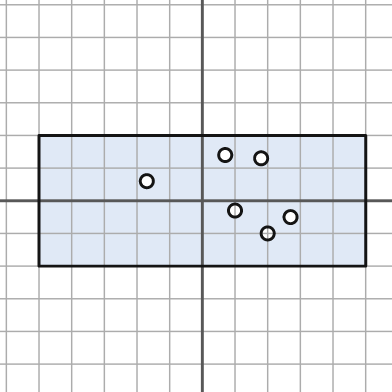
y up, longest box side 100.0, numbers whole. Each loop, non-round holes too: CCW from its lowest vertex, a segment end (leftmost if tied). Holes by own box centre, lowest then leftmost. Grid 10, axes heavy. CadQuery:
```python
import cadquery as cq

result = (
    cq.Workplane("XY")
    .moveTo(-50.0, -20.0)
    .lineTo(50.0, -20.0)
    .lineTo(50.0, 20.0)
    .lineTo(-50.0, 20.0)
    .close()
    .moveTo(20.0, -10.0)
    .circle(2.0)
    .moveTo(27.0, -5.0)
    .circle(2.0)
    .moveTo(10.0, -3.0)
    .circle(2.0)
    .moveTo(-17.0, 6.0)
    .circle(2.0)
    .moveTo(18.0, 13.0)
    .circle(2.0)
    .moveTo(7.0, 14.0)
    .circle(2.0)
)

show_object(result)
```